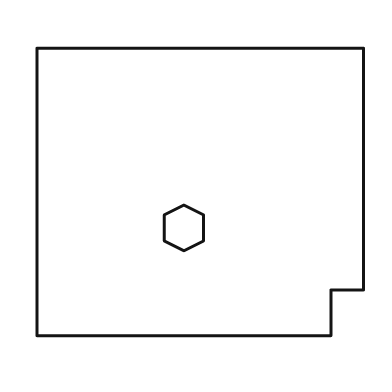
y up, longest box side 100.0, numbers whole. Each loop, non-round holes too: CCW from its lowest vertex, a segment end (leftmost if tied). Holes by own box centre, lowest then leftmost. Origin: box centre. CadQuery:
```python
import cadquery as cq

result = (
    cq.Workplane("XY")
    .moveTo(-50.0, -44.0)
    .lineTo(40.0, -44.0)
    .lineTo(40.0, -30.0)
    .lineTo(50.0, -30.0)
    .lineTo(50.0, 44.0)
    .lineTo(-50.0, 44.0)
    .close()
    .moveTo(-5.0, -18.0)
    .lineTo(1.0, -15.0)
    .lineTo(1.0, -7.0)
    .lineTo(-5.0, -4.0)
    .lineTo(-11.0, -7.0)
    .lineTo(-11.0, -15.0)
    .close()
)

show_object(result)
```